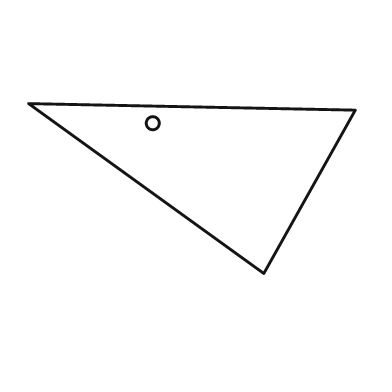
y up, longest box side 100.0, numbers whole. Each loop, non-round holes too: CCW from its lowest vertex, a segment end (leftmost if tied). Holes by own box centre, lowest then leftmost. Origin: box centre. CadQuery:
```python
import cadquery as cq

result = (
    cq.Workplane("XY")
    .moveTo(22.0, -26.0)
    .lineTo(50.0, 24.0)
    .lineTo(-50.0, 26.0)
    .close()
    .moveTo(-12.0, 20.0)
    .circle(2.0)
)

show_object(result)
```